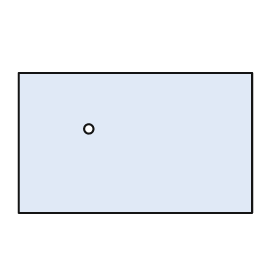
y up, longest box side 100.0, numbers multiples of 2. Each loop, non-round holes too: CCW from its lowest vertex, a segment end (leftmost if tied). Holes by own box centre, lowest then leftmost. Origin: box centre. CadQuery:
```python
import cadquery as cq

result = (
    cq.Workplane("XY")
    .moveTo(-50.0, -30.0)
    .lineTo(50.0, -30.0)
    .lineTo(50.0, 30.0)
    .lineTo(-50.0, 30.0)
    .close()
    .moveTo(-20.0, 6.0)
    .circle(2.0)
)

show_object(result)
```